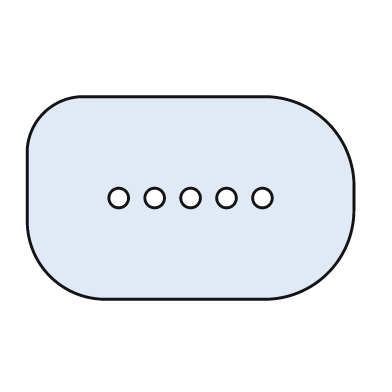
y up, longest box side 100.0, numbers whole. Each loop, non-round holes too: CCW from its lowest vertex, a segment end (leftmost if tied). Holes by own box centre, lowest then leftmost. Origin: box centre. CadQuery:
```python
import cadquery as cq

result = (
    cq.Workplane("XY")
    .moveTo(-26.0, -31.0)
    .lineTo(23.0, -31.0)
    .threePointArc((42.0, -23.0), (50.0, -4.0))
    .lineTo(50.0, 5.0)
    .threePointArc((42.0, 23.0), (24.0, 31.0))
    .lineTo(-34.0, 31.0)
    .threePointArc((-45.0, 26.0), (-50.0, 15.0))
    .lineTo(-50.0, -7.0)
    .threePointArc((-43.0, -24.0), (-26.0, -31.0))
    .close()
    .moveTo(-22.0, 0.0)
    .circle(3.0)
    .moveTo(-11.0, 0.0)
    .circle(3.0)
    .moveTo(0.0, 0.0)
    .circle(3.0)
    .moveTo(11.0, 0.0)
    .circle(3.0)
    .moveTo(22.0, 0.0)
    .circle(3.0)
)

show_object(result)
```